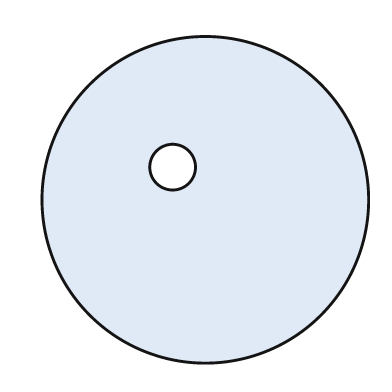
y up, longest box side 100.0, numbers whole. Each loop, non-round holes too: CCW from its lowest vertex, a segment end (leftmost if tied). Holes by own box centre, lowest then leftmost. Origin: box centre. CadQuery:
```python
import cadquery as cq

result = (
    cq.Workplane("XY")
    .moveTo(0.0, 0.0)
    .circle(50.0)
    .moveTo(-10.0, 10.0)
    .circle(7.0)
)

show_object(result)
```